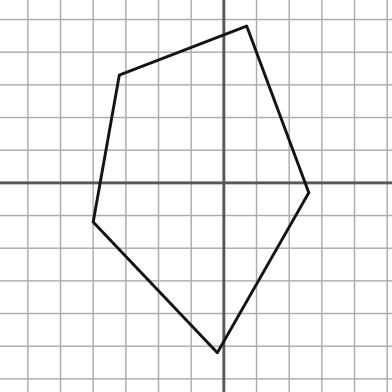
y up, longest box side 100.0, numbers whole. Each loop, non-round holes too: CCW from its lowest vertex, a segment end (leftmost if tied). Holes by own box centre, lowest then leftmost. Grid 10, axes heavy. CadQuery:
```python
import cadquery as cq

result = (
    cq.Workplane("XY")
    .moveTo(-2.0, -52.0)
    .lineTo(26.0, -3.0)
    .lineTo(7.0, 48.0)
    .lineTo(-32.0, 33.0)
    .lineTo(-40.0, -12.0)
    .close()
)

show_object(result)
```